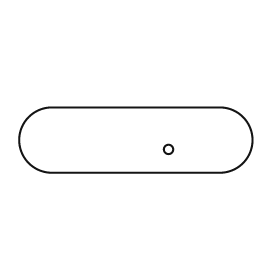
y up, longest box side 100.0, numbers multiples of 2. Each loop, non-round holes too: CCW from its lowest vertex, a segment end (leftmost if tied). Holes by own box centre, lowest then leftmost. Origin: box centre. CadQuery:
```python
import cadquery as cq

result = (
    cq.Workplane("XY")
    .moveTo(-36.0, -14.0)
    .lineTo(36.0, -14.0)
    .threePointArc((50.0, 0.0), (36.0, 14.0))
    .lineTo(-36.0, 14.0)
    .threePointArc((-50.0, 0.0), (-36.0, -14.0))
    .close()
    .moveTo(14.0, -4.0)
    .circle(2.0)
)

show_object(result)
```